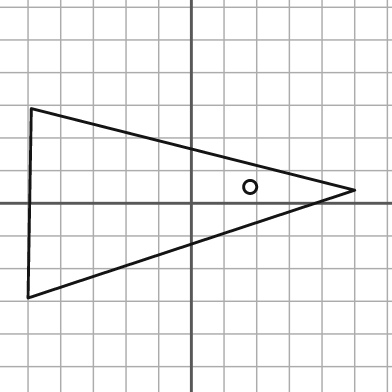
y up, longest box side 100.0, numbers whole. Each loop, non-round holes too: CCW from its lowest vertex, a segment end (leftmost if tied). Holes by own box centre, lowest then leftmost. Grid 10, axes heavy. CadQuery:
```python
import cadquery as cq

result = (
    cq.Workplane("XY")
    .moveTo(-50.0, -29.0)
    .lineTo(50.0, 4.0)
    .lineTo(-49.0, 29.0)
    .close()
    .moveTo(18.0, 5.0)
    .circle(2.0)
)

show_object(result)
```